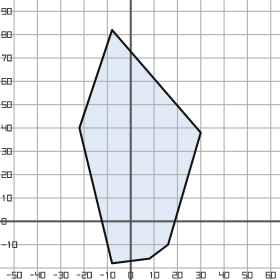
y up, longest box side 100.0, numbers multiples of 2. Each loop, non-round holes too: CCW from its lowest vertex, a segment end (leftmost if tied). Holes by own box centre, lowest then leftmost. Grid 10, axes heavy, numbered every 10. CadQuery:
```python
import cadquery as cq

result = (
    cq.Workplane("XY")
    .moveTo(-8.0, -18.0)
    .lineTo(8.0, -16.0)
    .lineTo(16.0, -10.0)
    .lineTo(30.0, 38.0)
    .lineTo(-8.0, 82.0)
    .lineTo(-22.0, 40.0)
    .close()
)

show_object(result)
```